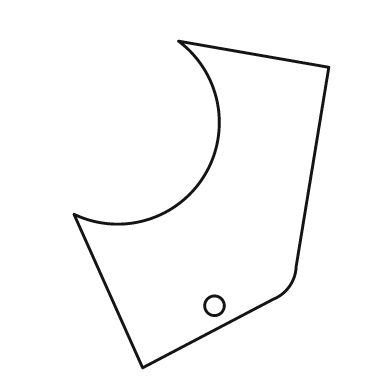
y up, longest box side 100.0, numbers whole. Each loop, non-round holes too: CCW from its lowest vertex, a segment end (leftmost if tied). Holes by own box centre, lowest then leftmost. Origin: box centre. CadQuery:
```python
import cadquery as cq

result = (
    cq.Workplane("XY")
    .moveTo(-18.0, -50.0)
    .lineTo(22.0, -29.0)
    .threePointArc((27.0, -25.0), (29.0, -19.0))
    .lineTo(39.0, 42.0)
    .lineTo(-7.0, 50.0)
    .threePointArc((1.0, 9.0), (-39.0, -3.0))
    .close()
    .moveTo(4.0, -31.0)
    .circle(3.0)
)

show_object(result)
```